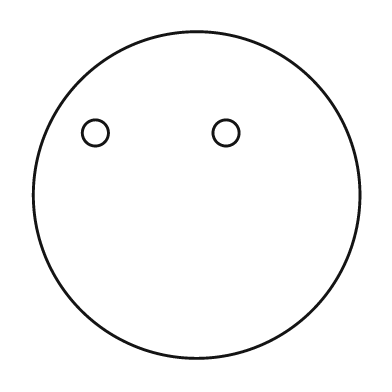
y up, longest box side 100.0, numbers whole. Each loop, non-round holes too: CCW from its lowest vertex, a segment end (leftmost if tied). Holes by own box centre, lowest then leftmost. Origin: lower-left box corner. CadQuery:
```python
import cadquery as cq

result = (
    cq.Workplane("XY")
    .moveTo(50.0, 50.0)
    .circle(50.0)
    .moveTo(19.0, 69.0)
    .circle(4.0)
    .moveTo(59.0, 69.0)
    .circle(4.0)
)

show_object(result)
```